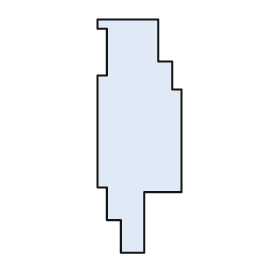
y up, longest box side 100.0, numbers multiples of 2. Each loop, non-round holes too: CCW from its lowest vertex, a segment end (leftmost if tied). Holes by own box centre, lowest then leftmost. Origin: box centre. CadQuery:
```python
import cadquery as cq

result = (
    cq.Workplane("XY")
    .moveTo(-8.0, -50.0)
    .lineTo(2.0, -50.0)
    .lineTo(2.0, -24.0)
    .lineTo(18.0, -24.0)
    .lineTo(18.0, 20.0)
    .lineTo(14.0, 20.0)
    .lineTo(14.0, 32.0)
    .lineTo(8.0, 32.0)
    .lineTo(8.0, 50.0)
    .lineTo(-18.0, 50.0)
    .lineTo(-18.0, 46.0)
    .lineTo(-14.0, 46.0)
    .lineTo(-14.0, 26.0)
    .lineTo(-18.0, 26.0)
    .lineTo(-18.0, -22.0)
    .lineTo(-14.0, -22.0)
    .lineTo(-14.0, -36.0)
    .lineTo(-8.0, -36.0)
    .close()
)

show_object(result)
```